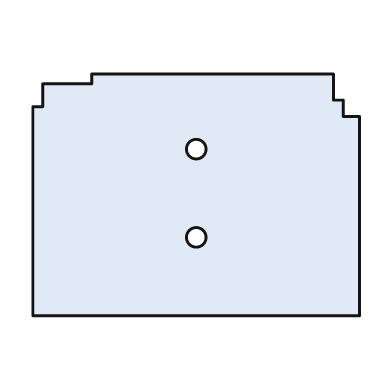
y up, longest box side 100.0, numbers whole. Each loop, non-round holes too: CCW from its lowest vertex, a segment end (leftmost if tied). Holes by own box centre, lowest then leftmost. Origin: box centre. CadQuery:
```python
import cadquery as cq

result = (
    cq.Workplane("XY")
    .moveTo(-50.0, -37.0)
    .lineTo(50.0, -37.0)
    .lineTo(50.0, 24.0)
    .lineTo(45.0, 24.0)
    .lineTo(45.0, 29.0)
    .lineTo(42.0, 29.0)
    .lineTo(42.0, 37.0)
    .lineTo(-32.0, 37.0)
    .lineTo(-32.0, 34.0)
    .lineTo(-47.0, 34.0)
    .lineTo(-47.0, 27.0)
    .lineTo(-50.0, 27.0)
    .close()
    .moveTo(0.0, -13.0)
    .circle(3.0)
    .moveTo(0.0, 14.0)
    .circle(3.0)
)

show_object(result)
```